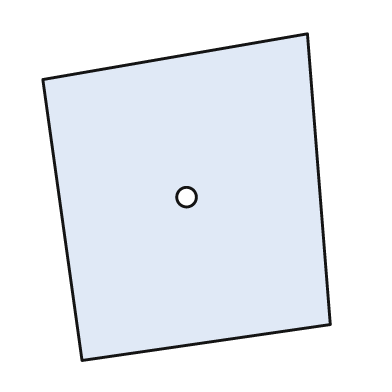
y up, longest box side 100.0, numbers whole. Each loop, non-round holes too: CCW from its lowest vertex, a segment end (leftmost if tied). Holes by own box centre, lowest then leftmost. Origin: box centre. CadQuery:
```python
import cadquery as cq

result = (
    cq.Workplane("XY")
    .moveTo(-32.0, -50.0)
    .lineTo(44.0, -39.0)
    .lineTo(37.0, 50.0)
    .lineTo(-44.0, 36.0)
    .close()
    .moveTo(0.0, 0.0)
    .circle(3.0)
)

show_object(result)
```